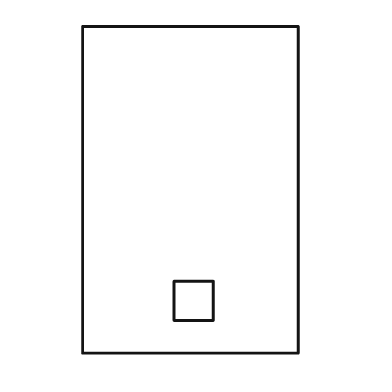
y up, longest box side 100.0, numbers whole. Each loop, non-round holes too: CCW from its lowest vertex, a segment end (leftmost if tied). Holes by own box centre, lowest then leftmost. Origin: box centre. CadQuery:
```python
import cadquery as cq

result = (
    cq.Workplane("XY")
    .moveTo(-33.0, -50.0)
    .lineTo(33.0, -50.0)
    .lineTo(33.0, 50.0)
    .lineTo(-33.0, 50.0)
    .close()
    .moveTo(-5.0, -40.0)
    .lineTo(7.0, -40.0)
    .lineTo(7.0, -28.0)
    .lineTo(-5.0, -28.0)
    .close()
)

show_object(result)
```